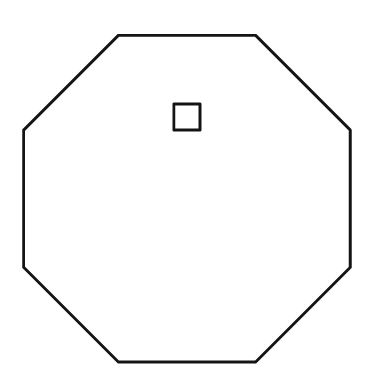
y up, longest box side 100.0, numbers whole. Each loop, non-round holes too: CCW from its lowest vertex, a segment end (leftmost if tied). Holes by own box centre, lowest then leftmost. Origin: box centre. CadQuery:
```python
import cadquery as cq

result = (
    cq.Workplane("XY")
    .moveTo(-21.0, -50.0)
    .lineTo(21.0, -50.0)
    .lineTo(50.0, -21.0)
    .lineTo(50.0, 21.0)
    .lineTo(21.0, 50.0)
    .lineTo(-21.0, 50.0)
    .lineTo(-50.0, 21.0)
    .lineTo(-50.0, -21.0)
    .close()
    .moveTo(-4.0, 21.0)
    .lineTo(4.0, 21.0)
    .lineTo(4.0, 29.0)
    .lineTo(-4.0, 29.0)
    .close()
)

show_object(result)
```